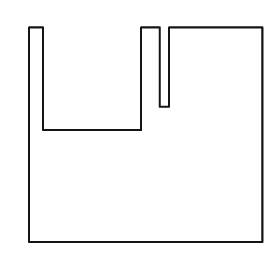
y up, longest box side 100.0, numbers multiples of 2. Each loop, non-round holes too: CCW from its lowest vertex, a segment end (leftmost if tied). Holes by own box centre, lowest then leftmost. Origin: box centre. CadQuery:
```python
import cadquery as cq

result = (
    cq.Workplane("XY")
    .moveTo(-50.0, -46.0)
    .lineTo(50.0, -46.0)
    .lineTo(50.0, 46.0)
    .lineTo(10.0, 46.0)
    .lineTo(10.0, 12.0)
    .lineTo(6.0, 12.0)
    .lineTo(6.0, 46.0)
    .lineTo(-2.0, 46.0)
    .lineTo(-2.0, 2.0)
    .lineTo(-44.0, 2.0)
    .lineTo(-44.0, 46.0)
    .lineTo(-50.0, 46.0)
    .close()
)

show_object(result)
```